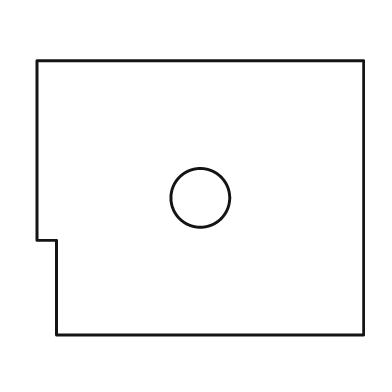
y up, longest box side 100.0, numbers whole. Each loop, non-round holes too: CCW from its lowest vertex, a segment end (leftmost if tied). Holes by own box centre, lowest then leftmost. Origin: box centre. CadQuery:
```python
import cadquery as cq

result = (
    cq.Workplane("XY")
    .moveTo(-44.0, -42.0)
    .lineTo(50.0, -42.0)
    .lineTo(50.0, 42.0)
    .lineTo(-50.0, 42.0)
    .lineTo(-50.0, -13.0)
    .lineTo(-44.0, -13.0)
    .close()
    .moveTo(0.0, 0.0)
    .circle(9.0)
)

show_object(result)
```